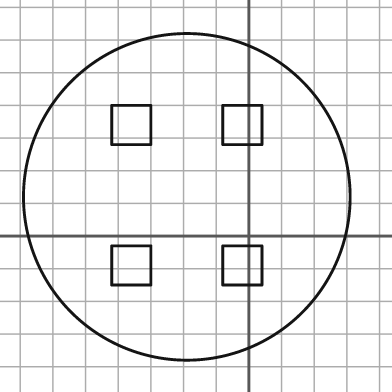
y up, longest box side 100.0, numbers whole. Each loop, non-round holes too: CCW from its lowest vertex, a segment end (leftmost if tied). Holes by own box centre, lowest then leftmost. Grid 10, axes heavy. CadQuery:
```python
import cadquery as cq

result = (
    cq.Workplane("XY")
    .moveTo(-19.0, 12.0)
    .circle(50.0)
    .moveTo(-42.0, -15.0)
    .lineTo(-30.0, -15.0)
    .lineTo(-30.0, -3.0)
    .lineTo(-42.0, -3.0)
    .close()
    .moveTo(-8.0, -15.0)
    .lineTo(4.0, -15.0)
    .lineTo(4.0, -3.0)
    .lineTo(-8.0, -3.0)
    .close()
    .moveTo(-42.0, 28.0)
    .lineTo(-30.0, 28.0)
    .lineTo(-30.0, 40.0)
    .lineTo(-42.0, 40.0)
    .close()
    .moveTo(-8.0, 28.0)
    .lineTo(4.0, 28.0)
    .lineTo(4.0, 40.0)
    .lineTo(-8.0, 40.0)
    .close()
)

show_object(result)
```